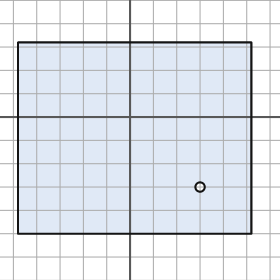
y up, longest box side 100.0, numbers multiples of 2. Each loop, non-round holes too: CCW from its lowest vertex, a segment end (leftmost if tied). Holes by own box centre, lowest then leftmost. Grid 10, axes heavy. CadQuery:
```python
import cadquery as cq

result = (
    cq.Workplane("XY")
    .moveTo(-48.0, -50.0)
    .lineTo(52.0, -50.0)
    .lineTo(52.0, 32.0)
    .lineTo(-48.0, 32.0)
    .close()
    .moveTo(30.0, -30.0)
    .circle(2.0)
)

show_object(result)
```